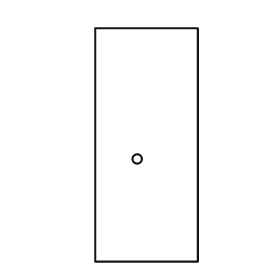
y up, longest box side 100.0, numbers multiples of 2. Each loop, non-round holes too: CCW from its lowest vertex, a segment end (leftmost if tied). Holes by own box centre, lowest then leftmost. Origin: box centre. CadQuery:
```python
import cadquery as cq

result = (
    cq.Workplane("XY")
    .moveTo(-22.0, -50.0)
    .lineTo(22.0, -50.0)
    .lineTo(22.0, 50.0)
    .lineTo(-22.0, 50.0)
    .close()
    .moveTo(-4.0, -6.0)
    .circle(2.0)
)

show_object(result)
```